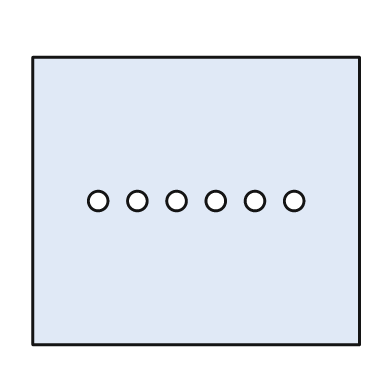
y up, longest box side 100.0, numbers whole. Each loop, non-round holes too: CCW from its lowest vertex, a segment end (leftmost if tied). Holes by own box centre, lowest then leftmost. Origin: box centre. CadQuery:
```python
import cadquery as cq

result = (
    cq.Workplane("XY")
    .moveTo(-50.0, -44.0)
    .lineTo(50.0, -44.0)
    .lineTo(50.0, 44.0)
    .lineTo(-50.0, 44.0)
    .close()
    .moveTo(-30.0, 0.0)
    .circle(3.0)
    .moveTo(-18.0, 0.0)
    .circle(3.0)
    .moveTo(-6.0, 0.0)
    .circle(3.0)
    .moveTo(6.0, 0.0)
    .circle(3.0)
    .moveTo(18.0, 0.0)
    .circle(3.0)
    .moveTo(30.0, 0.0)
    .circle(3.0)
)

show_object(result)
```